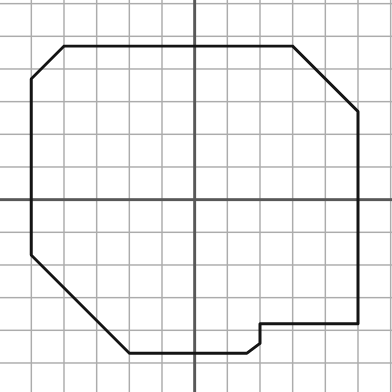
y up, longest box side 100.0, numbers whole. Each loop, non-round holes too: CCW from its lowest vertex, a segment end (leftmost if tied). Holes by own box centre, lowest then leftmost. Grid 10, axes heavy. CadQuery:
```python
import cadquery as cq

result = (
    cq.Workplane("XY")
    .moveTo(-20.0, -47.0)
    .lineTo(16.0, -47.0)
    .lineTo(20.0, -44.0)
    .lineTo(20.0, -38.0)
    .lineTo(50.0, -38.0)
    .lineTo(50.0, 27.0)
    .lineTo(30.0, 47.0)
    .lineTo(-40.0, 47.0)
    .lineTo(-50.0, 37.0)
    .lineTo(-50.0, -17.0)
    .close()
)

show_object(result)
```